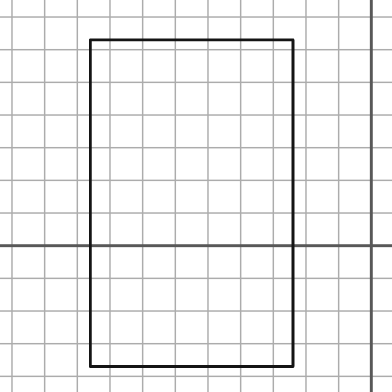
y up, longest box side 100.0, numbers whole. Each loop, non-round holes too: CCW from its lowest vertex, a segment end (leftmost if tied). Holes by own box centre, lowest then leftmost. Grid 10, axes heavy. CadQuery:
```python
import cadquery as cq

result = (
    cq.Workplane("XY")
    .moveTo(-86.0, -37.0)
    .lineTo(-24.0, -37.0)
    .lineTo(-24.0, 63.0)
    .lineTo(-86.0, 63.0)
    .close()
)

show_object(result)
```